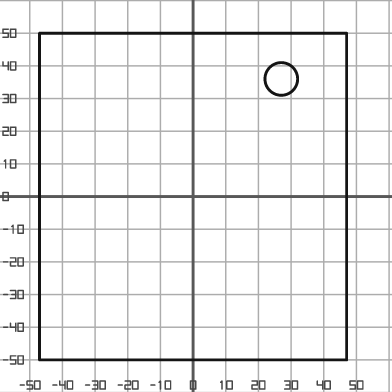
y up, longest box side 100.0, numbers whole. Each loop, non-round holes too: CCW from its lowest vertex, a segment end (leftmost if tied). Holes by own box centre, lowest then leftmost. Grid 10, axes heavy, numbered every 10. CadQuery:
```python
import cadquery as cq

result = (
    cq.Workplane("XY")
    .moveTo(-47.0, -50.0)
    .lineTo(47.0, -50.0)
    .lineTo(47.0, 50.0)
    .lineTo(-47.0, 50.0)
    .close()
    .moveTo(27.0, 36.0)
    .circle(5.0)
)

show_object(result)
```